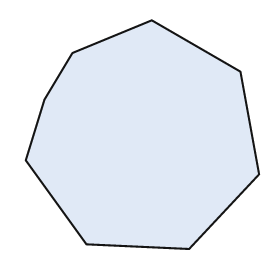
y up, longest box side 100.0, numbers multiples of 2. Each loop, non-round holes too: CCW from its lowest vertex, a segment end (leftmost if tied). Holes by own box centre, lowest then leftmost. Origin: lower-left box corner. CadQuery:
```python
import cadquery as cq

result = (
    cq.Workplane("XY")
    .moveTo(70.0, 0.0)
    .lineTo(100.0, 32.0)
    .lineTo(92.0, 76.0)
    .lineTo(54.0, 98.0)
    .lineTo(20.0, 84.0)
    .lineTo(8.0, 64.0)
    .lineTo(0.0, 38.0)
    .lineTo(26.0, 2.0)
    .close()
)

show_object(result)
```